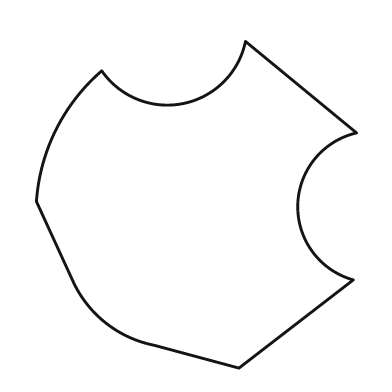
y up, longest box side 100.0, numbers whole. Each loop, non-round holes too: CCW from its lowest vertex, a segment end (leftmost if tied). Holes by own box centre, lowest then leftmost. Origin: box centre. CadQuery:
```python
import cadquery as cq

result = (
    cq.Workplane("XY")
    .moveTo(13.0, -50.0)
    .lineTo(48.0, -23.0)
    .threePointArc((31.0, 0.0), (49.0, 22.0))
    .lineTo(15.0, 50.0)
    .threePointArc((-4.0, 31.0), (-29.0, 41.0))
    .threePointArc((-43.0, 23.0), (-49.0, 1.0))
    .lineTo(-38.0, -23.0)
    .threePointArc((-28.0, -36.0), (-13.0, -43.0))
    .close()
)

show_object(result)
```